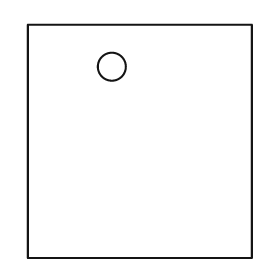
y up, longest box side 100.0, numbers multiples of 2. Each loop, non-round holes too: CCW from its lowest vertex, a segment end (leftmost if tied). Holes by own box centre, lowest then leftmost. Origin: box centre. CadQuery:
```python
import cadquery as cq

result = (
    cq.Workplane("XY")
    .moveTo(-48.0, -50.0)
    .lineTo(48.0, -50.0)
    .lineTo(48.0, 50.0)
    .lineTo(-48.0, 50.0)
    .close()
    .moveTo(-12.0, 32.0)
    .circle(6.0)
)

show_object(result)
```